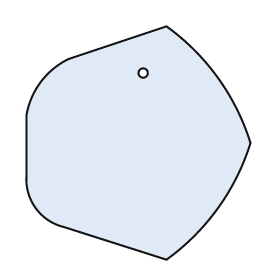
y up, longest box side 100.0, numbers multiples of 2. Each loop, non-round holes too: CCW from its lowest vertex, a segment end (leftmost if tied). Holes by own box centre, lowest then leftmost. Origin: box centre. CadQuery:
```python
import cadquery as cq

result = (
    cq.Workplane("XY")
    .moveTo(12.0, -50.0)
    .threePointArc((34.0, -28.0), (48.0, 0.0))
    .threePointArc((34.0, 28.0), (12.0, 50.0))
    .lineTo(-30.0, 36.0)
    .threePointArc((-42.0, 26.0), (-48.0, 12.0))
    .lineTo(-48.0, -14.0)
    .threePointArc((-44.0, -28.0), (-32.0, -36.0))
    .close()
    .moveTo(2.0, 30.0)
    .circle(2.0)
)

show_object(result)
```